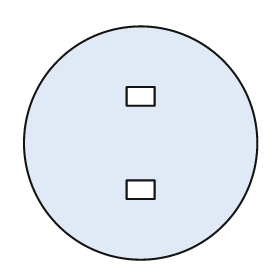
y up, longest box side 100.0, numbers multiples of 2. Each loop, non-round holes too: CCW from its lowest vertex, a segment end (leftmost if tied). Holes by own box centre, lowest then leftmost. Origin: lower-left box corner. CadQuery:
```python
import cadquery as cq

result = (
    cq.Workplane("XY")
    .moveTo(50.0, 50.0)
    .circle(50.0)
    .moveTo(44.0, 26.0)
    .lineTo(56.0, 26.0)
    .lineTo(56.0, 34.0)
    .lineTo(44.0, 34.0)
    .close()
    .moveTo(44.0, 66.0)
    .lineTo(56.0, 66.0)
    .lineTo(56.0, 74.0)
    .lineTo(44.0, 74.0)
    .close()
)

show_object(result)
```